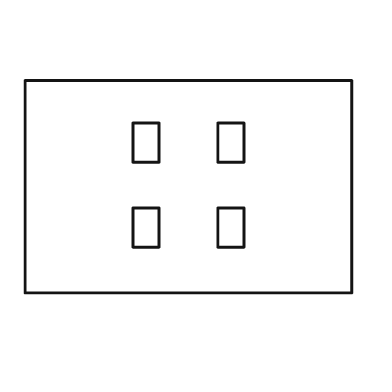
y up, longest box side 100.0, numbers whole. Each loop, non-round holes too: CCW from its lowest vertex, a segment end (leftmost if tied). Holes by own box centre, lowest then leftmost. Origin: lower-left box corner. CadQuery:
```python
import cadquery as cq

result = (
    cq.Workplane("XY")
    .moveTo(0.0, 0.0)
    .lineTo(100.0, 0.0)
    .lineTo(100.0, 65.0)
    .lineTo(0.0, 65.0)
    .close()
    .moveTo(33.0, 14.0)
    .lineTo(41.0, 14.0)
    .lineTo(41.0, 26.0)
    .lineTo(33.0, 26.0)
    .close()
    .moveTo(59.0, 14.0)
    .lineTo(67.0, 14.0)
    .lineTo(67.0, 26.0)
    .lineTo(59.0, 26.0)
    .close()
    .moveTo(33.0, 40.0)
    .lineTo(41.0, 40.0)
    .lineTo(41.0, 52.0)
    .lineTo(33.0, 52.0)
    .close()
    .moveTo(59.0, 40.0)
    .lineTo(67.0, 40.0)
    .lineTo(67.0, 52.0)
    .lineTo(59.0, 52.0)
    .close()
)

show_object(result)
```